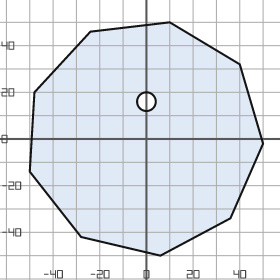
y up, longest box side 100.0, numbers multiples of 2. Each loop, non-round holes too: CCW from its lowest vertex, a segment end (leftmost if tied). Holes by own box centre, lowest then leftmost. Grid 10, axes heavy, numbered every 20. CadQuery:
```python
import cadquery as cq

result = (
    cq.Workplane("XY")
    .moveTo(6.0, -50.0)
    .lineTo(36.0, -34.0)
    .lineTo(50.0, -2.0)
    .lineTo(40.0, 32.0)
    .lineTo(10.0, 50.0)
    .lineTo(-24.0, 46.0)
    .lineTo(-48.0, 20.0)
    .lineTo(-50.0, -14.0)
    .lineTo(-28.0, -42.0)
    .close()
    .moveTo(0.0, 16.0)
    .circle(4.0)
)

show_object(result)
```